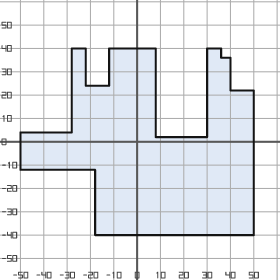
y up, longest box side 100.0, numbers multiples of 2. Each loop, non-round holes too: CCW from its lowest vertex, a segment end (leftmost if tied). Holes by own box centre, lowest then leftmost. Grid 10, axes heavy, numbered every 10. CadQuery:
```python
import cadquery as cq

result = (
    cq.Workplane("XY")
    .moveTo(-18.0, -40.0)
    .lineTo(50.0, -40.0)
    .lineTo(50.0, 22.0)
    .lineTo(40.0, 22.0)
    .lineTo(40.0, 36.0)
    .lineTo(36.0, 36.0)
    .lineTo(36.0, 40.0)
    .lineTo(30.0, 40.0)
    .lineTo(30.0, 2.0)
    .lineTo(8.0, 2.0)
    .lineTo(8.0, 40.0)
    .lineTo(-12.0, 40.0)
    .lineTo(-12.0, 24.0)
    .lineTo(-22.0, 24.0)
    .lineTo(-22.0, 40.0)
    .lineTo(-28.0, 40.0)
    .lineTo(-28.0, 4.0)
    .lineTo(-50.0, 4.0)
    .lineTo(-50.0, -12.0)
    .lineTo(-18.0, -12.0)
    .close()
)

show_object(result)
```